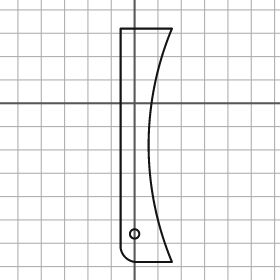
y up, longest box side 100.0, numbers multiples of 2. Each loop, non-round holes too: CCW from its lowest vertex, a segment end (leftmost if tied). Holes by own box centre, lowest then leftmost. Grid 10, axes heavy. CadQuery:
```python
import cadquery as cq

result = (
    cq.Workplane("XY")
    .moveTo(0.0, -68.0)
    .lineTo(16.0, -68.0)
    .threePointArc((6.0, -18.0), (16.0, 32.0))
    .lineTo(-6.0, 32.0)
    .lineTo(-6.0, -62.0)
    .threePointArc((-4.0, -66.0), (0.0, -68.0))
    .close()
    .moveTo(0.0, -56.0)
    .circle(2.0)
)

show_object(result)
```